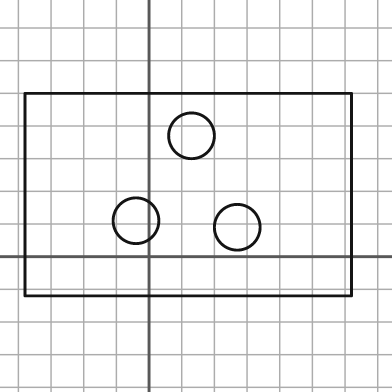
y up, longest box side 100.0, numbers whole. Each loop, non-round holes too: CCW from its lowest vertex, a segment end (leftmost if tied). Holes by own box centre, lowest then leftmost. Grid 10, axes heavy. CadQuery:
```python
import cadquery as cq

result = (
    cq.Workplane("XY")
    .moveTo(-38.0, -12.0)
    .lineTo(62.0, -12.0)
    .lineTo(62.0, 50.0)
    .lineTo(-38.0, 50.0)
    .close()
    .moveTo(27.0, 9.0)
    .circle(7.0)
    .moveTo(-4.0, 11.0)
    .circle(7.0)
    .moveTo(13.0, 37.0)
    .circle(7.0)
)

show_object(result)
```